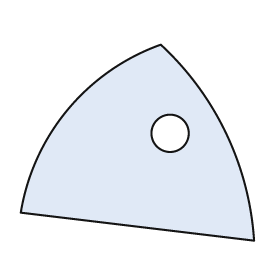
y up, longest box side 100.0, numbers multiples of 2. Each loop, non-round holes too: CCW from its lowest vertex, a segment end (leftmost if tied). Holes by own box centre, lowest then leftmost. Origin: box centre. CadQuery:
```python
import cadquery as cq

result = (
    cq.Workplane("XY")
    .moveTo(50.0, -42.0)
    .threePointArc((38.0, 4.0), (10.0, 42.0))
    .threePointArc((-30.0, 14.0), (-50.0, -30.0))
    .close()
    .moveTo(14.0, 4.0)
    .circle(8.0)
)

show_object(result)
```